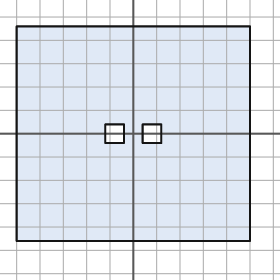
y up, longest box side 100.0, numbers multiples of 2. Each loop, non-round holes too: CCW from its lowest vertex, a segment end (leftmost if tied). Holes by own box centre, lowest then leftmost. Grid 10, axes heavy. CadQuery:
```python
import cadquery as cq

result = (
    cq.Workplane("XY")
    .moveTo(-50.0, -46.0)
    .lineTo(50.0, -46.0)
    .lineTo(50.0, 46.0)
    .lineTo(-50.0, 46.0)
    .close()
    .moveTo(-12.0, -4.0)
    .lineTo(-4.0, -4.0)
    .lineTo(-4.0, 4.0)
    .lineTo(-12.0, 4.0)
    .close()
    .moveTo(4.0, -4.0)
    .lineTo(12.0, -4.0)
    .lineTo(12.0, 4.0)
    .lineTo(4.0, 4.0)
    .close()
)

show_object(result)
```